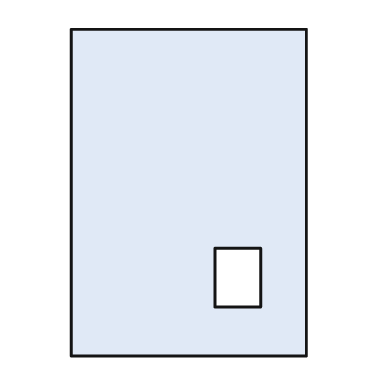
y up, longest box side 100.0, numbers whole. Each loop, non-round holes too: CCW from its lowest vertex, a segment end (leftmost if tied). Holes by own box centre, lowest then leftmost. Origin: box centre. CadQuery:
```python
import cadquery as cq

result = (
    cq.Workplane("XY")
    .moveTo(-36.0, -50.0)
    .lineTo(36.0, -50.0)
    .lineTo(36.0, 50.0)
    .lineTo(-36.0, 50.0)
    .close()
    .moveTo(8.0, -35.0)
    .lineTo(22.0, -35.0)
    .lineTo(22.0, -17.0)
    .lineTo(8.0, -17.0)
    .close()
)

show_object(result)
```